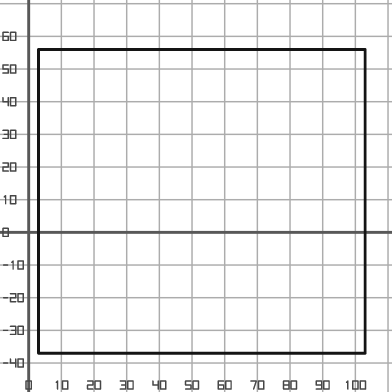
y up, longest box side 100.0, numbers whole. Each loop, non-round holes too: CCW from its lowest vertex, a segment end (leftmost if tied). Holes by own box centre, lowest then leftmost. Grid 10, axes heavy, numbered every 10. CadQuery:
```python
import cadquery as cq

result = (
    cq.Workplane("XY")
    .moveTo(3.0, -37.0)
    .lineTo(103.0, -37.0)
    .lineTo(103.0, 56.0)
    .lineTo(3.0, 56.0)
    .close()
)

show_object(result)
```